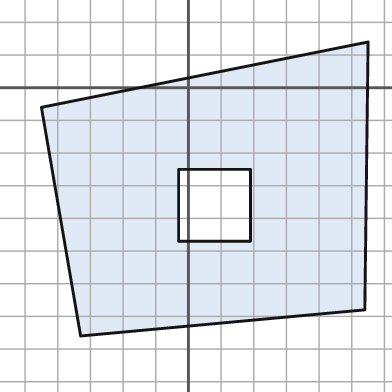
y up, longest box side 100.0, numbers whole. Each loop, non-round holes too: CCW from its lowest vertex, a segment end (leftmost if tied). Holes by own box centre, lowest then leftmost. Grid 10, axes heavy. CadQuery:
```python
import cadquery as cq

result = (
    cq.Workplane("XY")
    .moveTo(-33.0, -76.0)
    .lineTo(54.0, -68.0)
    .lineTo(55.0, 14.0)
    .lineTo(-45.0, -6.0)
    .close()
    .moveTo(-3.0, -47.0)
    .lineTo(19.0, -47.0)
    .lineTo(19.0, -25.0)
    .lineTo(-3.0, -25.0)
    .close()
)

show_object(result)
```